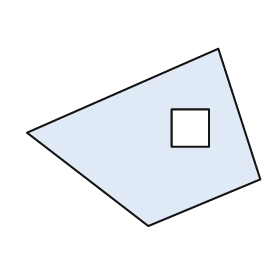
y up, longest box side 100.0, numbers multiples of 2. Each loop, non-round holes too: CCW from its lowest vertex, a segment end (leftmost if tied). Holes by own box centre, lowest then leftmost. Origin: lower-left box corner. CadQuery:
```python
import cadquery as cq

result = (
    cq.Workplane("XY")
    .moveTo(52.0, 0.0)
    .lineTo(100.0, 20.0)
    .lineTo(82.0, 76.0)
    .lineTo(0.0, 40.0)
    .close()
    .moveTo(62.0, 34.0)
    .lineTo(78.0, 34.0)
    .lineTo(78.0, 50.0)
    .lineTo(62.0, 50.0)
    .close()
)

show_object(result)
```